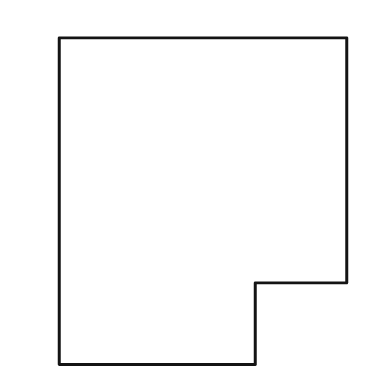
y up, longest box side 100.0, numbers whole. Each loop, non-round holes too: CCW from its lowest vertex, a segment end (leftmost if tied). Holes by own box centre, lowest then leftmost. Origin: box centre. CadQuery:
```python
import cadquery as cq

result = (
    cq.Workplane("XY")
    .moveTo(-44.0, -50.0)
    .lineTo(16.0, -50.0)
    .lineTo(16.0, -25.0)
    .lineTo(44.0, -25.0)
    .lineTo(44.0, 50.0)
    .lineTo(-44.0, 50.0)
    .close()
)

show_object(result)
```